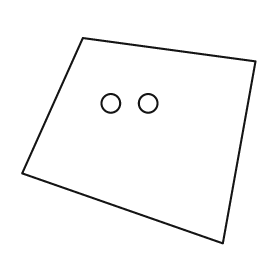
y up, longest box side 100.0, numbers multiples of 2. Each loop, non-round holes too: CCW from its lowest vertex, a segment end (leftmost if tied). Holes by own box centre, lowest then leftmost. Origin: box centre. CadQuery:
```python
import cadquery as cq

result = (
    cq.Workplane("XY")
    .moveTo(36.0, -44.0)
    .lineTo(50.0, 34.0)
    .lineTo(-24.0, 44.0)
    .lineTo(-50.0, -14.0)
    .close()
    .moveTo(-12.0, 16.0)
    .circle(4.0)
    .moveTo(4.0, 16.0)
    .circle(4.0)
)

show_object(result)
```